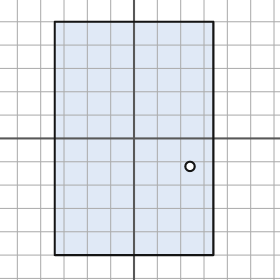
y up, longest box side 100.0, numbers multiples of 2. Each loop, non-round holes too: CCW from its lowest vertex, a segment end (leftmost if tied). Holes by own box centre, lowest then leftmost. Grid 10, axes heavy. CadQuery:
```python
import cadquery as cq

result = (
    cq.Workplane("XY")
    .moveTo(-34.0, -50.0)
    .lineTo(34.0, -50.0)
    .lineTo(34.0, 50.0)
    .lineTo(-34.0, 50.0)
    .close()
    .moveTo(24.0, -12.0)
    .circle(2.0)
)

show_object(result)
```